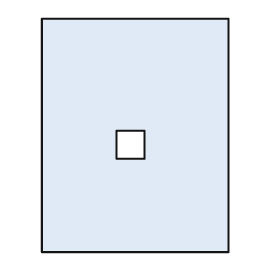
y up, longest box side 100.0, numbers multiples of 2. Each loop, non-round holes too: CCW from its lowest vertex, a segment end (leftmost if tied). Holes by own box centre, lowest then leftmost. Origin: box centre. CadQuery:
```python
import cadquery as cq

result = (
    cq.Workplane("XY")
    .moveTo(-40.0, -50.0)
    .lineTo(40.0, -50.0)
    .lineTo(40.0, 50.0)
    .lineTo(-40.0, 50.0)
    .close()
    .moveTo(-8.0, -10.0)
    .lineTo(4.0, -10.0)
    .lineTo(4.0, 2.0)
    .lineTo(-8.0, 2.0)
    .close()
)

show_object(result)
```